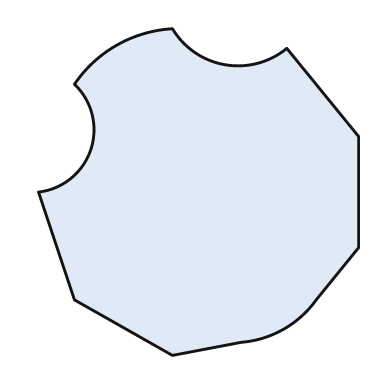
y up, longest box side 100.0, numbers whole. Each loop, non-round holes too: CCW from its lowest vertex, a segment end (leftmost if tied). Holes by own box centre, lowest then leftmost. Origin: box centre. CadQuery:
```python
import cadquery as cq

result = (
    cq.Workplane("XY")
    .moveTo(-8.0, -50.0)
    .lineTo(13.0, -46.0)
    .threePointArc((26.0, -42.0), (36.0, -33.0))
    .lineTo(49.0, -17.0)
    .lineTo(49.0, 17.0)
    .lineTo(27.0, 44.0)
    .threePointArc((8.0, 39.0), (-8.0, 50.0))
    .threePointArc((-25.0, 45.0), (-38.0, 33.0))
    .threePointArc((-33.0, 13.0), (-49.0, 0.0))
    .lineTo(-38.0, -33.0)
    .close()
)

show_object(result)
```